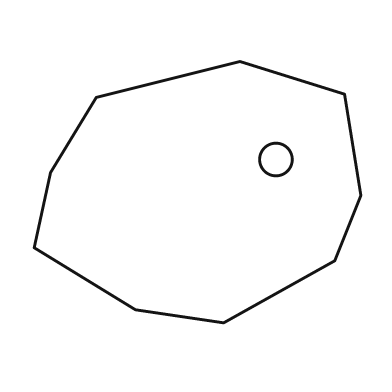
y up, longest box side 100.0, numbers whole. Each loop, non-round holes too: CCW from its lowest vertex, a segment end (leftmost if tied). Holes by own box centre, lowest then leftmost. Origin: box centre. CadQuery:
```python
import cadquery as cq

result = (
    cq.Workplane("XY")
    .moveTo(8.0, -40.0)
    .lineTo(42.0, -21.0)
    .lineTo(50.0, -1.0)
    .lineTo(45.0, 30.0)
    .lineTo(13.0, 40.0)
    .lineTo(-31.0, 29.0)
    .lineTo(-45.0, 6.0)
    .lineTo(-50.0, -17.0)
    .lineTo(-19.0, -36.0)
    .close()
    .moveTo(24.0, 10.0)
    .circle(5.0)
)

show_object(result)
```